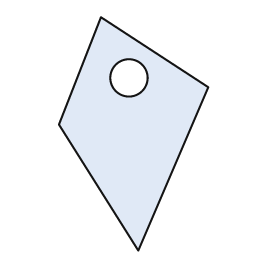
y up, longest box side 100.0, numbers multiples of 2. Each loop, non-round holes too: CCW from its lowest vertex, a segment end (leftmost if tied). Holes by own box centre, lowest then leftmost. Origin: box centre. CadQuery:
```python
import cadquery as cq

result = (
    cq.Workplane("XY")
    .moveTo(2.0, -50.0)
    .lineTo(32.0, 20.0)
    .lineTo(-14.0, 50.0)
    .lineTo(-32.0, 4.0)
    .close()
    .moveTo(-2.0, 24.0)
    .circle(8.0)
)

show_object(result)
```